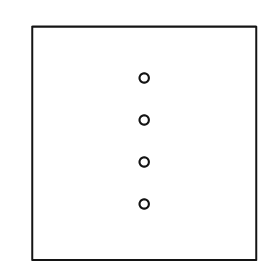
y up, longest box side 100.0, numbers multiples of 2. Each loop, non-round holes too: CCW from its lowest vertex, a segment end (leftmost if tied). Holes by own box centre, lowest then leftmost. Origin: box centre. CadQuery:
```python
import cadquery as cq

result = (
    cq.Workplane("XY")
    .moveTo(-48.0, -50.0)
    .lineTo(48.0, -50.0)
    .lineTo(48.0, 50.0)
    .lineTo(-48.0, 50.0)
    .close()
    .moveTo(0.0, -26.0)
    .circle(2.0)
    .moveTo(0.0, -8.0)
    .circle(2.0)
    .moveTo(0.0, 10.0)
    .circle(2.0)
    .moveTo(0.0, 28.0)
    .circle(2.0)
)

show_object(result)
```